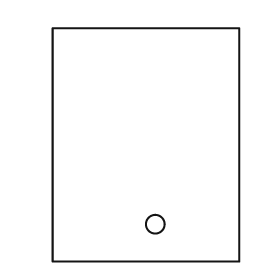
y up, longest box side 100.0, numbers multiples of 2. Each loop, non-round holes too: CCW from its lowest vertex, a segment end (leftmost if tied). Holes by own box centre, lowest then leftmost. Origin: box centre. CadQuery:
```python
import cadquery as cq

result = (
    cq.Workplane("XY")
    .moveTo(-40.0, -50.0)
    .lineTo(40.0, -50.0)
    .lineTo(40.0, 50.0)
    .lineTo(-40.0, 50.0)
    .close()
    .moveTo(4.0, -34.0)
    .circle(4.0)
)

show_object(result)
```